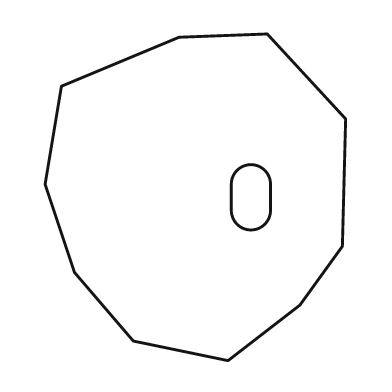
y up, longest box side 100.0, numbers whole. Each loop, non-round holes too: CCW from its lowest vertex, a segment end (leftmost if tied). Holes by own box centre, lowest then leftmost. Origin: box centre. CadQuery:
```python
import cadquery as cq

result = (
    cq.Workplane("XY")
    .moveTo(10.0, -50.0)
    .lineTo(32.0, -33.0)
    .lineTo(45.0, -15.0)
    .lineTo(46.0, 24.0)
    .lineTo(22.0, 50.0)
    .lineTo(-5.0, 49.0)
    .lineTo(-41.0, 34.0)
    .lineTo(-46.0, 4.0)
    .lineTo(-37.0, -23.0)
    .lineTo(-19.0, -44.0)
    .close()
    .moveTo(11.0, -4.0)
    .threePointArc((17.0, -10.0), (23.0, -4.0))
    .lineTo(23.0, 4.0)
    .threePointArc((17.0, 10.0), (11.0, 4.0))
    .close()
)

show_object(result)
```